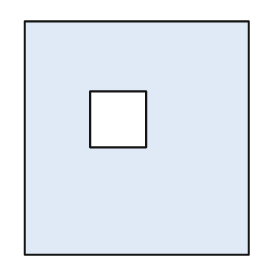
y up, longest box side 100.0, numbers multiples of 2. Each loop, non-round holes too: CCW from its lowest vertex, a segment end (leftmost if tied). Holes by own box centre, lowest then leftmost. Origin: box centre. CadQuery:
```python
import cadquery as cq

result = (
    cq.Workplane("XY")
    .moveTo(-48.0, -50.0)
    .lineTo(48.0, -50.0)
    .lineTo(48.0, 50.0)
    .lineTo(-48.0, 50.0)
    .close()
    .moveTo(-20.0, -4.0)
    .lineTo(4.0, -4.0)
    .lineTo(4.0, 20.0)
    .lineTo(-20.0, 20.0)
    .close()
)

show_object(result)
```